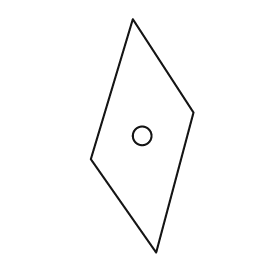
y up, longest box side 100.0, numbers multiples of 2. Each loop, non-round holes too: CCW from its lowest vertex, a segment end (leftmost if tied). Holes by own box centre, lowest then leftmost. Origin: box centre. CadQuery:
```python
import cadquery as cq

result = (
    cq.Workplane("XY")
    .moveTo(6.0, -50.0)
    .lineTo(22.0, 10.0)
    .lineTo(-4.0, 50.0)
    .lineTo(-22.0, -10.0)
    .close()
    .moveTo(0.0, 0.0)
    .circle(4.0)
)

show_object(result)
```